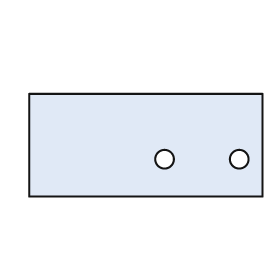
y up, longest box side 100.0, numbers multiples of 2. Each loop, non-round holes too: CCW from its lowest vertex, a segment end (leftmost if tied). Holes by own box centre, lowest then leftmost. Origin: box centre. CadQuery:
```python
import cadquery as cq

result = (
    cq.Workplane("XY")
    .moveTo(-50.0, -22.0)
    .lineTo(50.0, -22.0)
    .lineTo(50.0, 22.0)
    .lineTo(-50.0, 22.0)
    .close()
    .moveTo(8.0, -6.0)
    .circle(4.0)
    .moveTo(40.0, -6.0)
    .circle(4.0)
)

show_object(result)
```